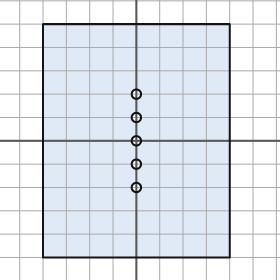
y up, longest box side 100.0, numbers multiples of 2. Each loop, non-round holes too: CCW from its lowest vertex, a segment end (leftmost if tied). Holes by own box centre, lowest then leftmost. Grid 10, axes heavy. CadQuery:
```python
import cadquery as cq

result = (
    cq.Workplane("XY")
    .moveTo(-40.0, -50.0)
    .lineTo(40.0, -50.0)
    .lineTo(40.0, 50.0)
    .lineTo(-40.0, 50.0)
    .close()
    .moveTo(0.0, -20.0)
    .circle(2.0)
    .moveTo(0.0, -10.0)
    .circle(2.0)
    .moveTo(0.0, 0.0)
    .circle(2.0)
    .moveTo(0.0, 10.0)
    .circle(2.0)
    .moveTo(0.0, 20.0)
    .circle(2.0)
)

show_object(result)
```